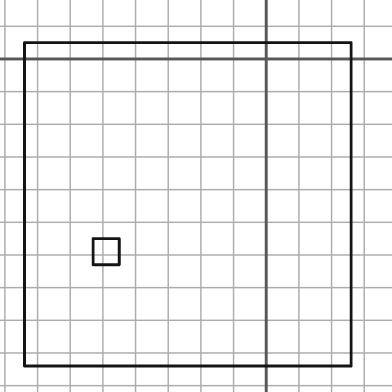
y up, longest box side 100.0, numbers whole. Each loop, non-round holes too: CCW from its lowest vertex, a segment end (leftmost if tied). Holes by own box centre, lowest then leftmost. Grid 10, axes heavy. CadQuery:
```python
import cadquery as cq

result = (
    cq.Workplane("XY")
    .moveTo(-74.0, -94.0)
    .lineTo(26.0, -94.0)
    .lineTo(26.0, 5.0)
    .lineTo(-74.0, 5.0)
    .close()
    .moveTo(-53.0, -63.0)
    .lineTo(-45.0, -63.0)
    .lineTo(-45.0, -55.0)
    .lineTo(-53.0, -55.0)
    .close()
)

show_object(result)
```